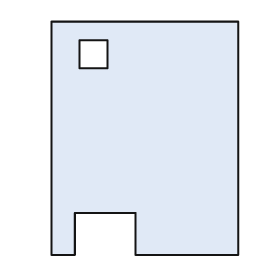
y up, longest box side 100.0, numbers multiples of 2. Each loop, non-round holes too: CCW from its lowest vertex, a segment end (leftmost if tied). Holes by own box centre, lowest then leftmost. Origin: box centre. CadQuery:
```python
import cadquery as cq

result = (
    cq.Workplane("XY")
    .moveTo(-40.0, -50.0)
    .lineTo(-30.0, -50.0)
    .lineTo(-30.0, -32.0)
    .lineTo(-4.0, -32.0)
    .lineTo(-4.0, -50.0)
    .lineTo(40.0, -50.0)
    .lineTo(40.0, 50.0)
    .lineTo(-40.0, 50.0)
    .close()
    .moveTo(-28.0, 30.0)
    .lineTo(-16.0, 30.0)
    .lineTo(-16.0, 42.0)
    .lineTo(-28.0, 42.0)
    .close()
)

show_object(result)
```